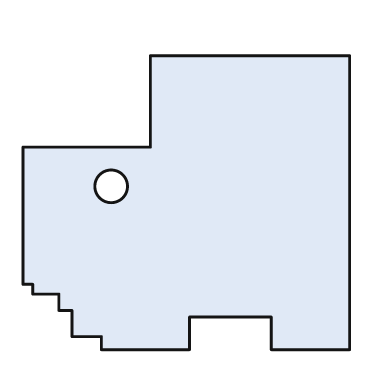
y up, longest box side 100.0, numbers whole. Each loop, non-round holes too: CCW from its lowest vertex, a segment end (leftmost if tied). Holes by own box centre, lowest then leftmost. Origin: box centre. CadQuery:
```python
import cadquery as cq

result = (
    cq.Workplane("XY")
    .moveTo(-26.0, -45.0)
    .lineTo(1.0, -45.0)
    .lineTo(1.0, -35.0)
    .lineTo(26.0, -35.0)
    .lineTo(26.0, -45.0)
    .lineTo(50.0, -45.0)
    .lineTo(50.0, 45.0)
    .lineTo(-11.0, 45.0)
    .lineTo(-11.0, 17.0)
    .lineTo(-50.0, 17.0)
    .lineTo(-50.0, -25.0)
    .lineTo(-47.0, -25.0)
    .lineTo(-47.0, -28.0)
    .lineTo(-39.0, -28.0)
    .lineTo(-39.0, -33.0)
    .lineTo(-35.0, -33.0)
    .lineTo(-35.0, -41.0)
    .lineTo(-26.0, -41.0)
    .close()
    .moveTo(-23.0, 5.0)
    .circle(5.0)
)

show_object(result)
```